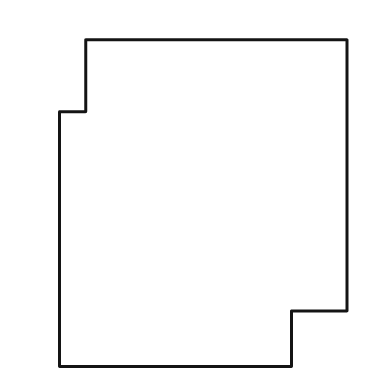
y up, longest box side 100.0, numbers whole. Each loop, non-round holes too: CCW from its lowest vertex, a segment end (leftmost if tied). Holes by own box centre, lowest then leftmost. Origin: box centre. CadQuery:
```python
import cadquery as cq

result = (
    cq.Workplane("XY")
    .moveTo(-44.0, -50.0)
    .lineTo(27.0, -50.0)
    .lineTo(27.0, -33.0)
    .lineTo(44.0, -33.0)
    .lineTo(44.0, 50.0)
    .lineTo(-36.0, 50.0)
    .lineTo(-36.0, 28.0)
    .lineTo(-44.0, 28.0)
    .close()
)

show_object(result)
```